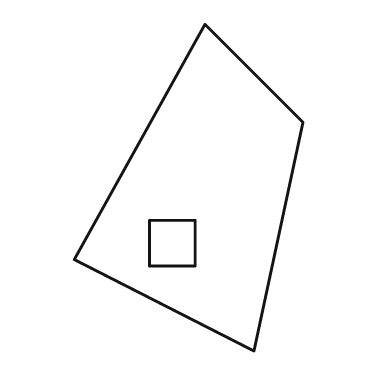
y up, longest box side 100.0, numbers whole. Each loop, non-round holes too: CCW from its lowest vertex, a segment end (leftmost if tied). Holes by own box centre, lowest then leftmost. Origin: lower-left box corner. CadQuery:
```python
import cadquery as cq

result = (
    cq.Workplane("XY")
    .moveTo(55.0, 0.0)
    .lineTo(70.0, 70.0)
    .lineTo(40.0, 100.0)
    .lineTo(0.0, 28.0)
    .close()
    .moveTo(23.0, 26.0)
    .lineTo(37.0, 26.0)
    .lineTo(37.0, 40.0)
    .lineTo(23.0, 40.0)
    .close()
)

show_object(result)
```